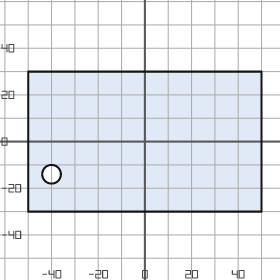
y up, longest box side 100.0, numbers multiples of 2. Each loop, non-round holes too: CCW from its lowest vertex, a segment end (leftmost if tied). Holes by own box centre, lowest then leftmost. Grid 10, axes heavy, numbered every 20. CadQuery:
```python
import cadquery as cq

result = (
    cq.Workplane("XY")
    .moveTo(-50.0, -30.0)
    .lineTo(50.0, -30.0)
    .lineTo(50.0, 30.0)
    .lineTo(-50.0, 30.0)
    .close()
    .moveTo(-40.0, -14.0)
    .circle(4.0)
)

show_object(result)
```